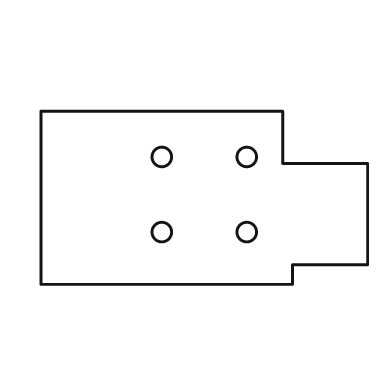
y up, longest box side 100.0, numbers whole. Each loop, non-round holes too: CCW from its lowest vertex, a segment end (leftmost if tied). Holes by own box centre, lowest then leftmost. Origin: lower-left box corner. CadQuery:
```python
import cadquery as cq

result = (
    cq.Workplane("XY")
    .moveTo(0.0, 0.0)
    .lineTo(77.0, 0.0)
    .lineTo(77.0, 6.0)
    .lineTo(100.0, 6.0)
    .lineTo(100.0, 37.0)
    .lineTo(74.0, 37.0)
    .lineTo(74.0, 53.0)
    .lineTo(0.0, 53.0)
    .close()
    .moveTo(37.0, 16.0)
    .circle(3.0)
    .moveTo(63.0, 16.0)
    .circle(3.0)
    .moveTo(37.0, 39.0)
    .circle(3.0)
    .moveTo(63.0, 39.0)
    .circle(3.0)
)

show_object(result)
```